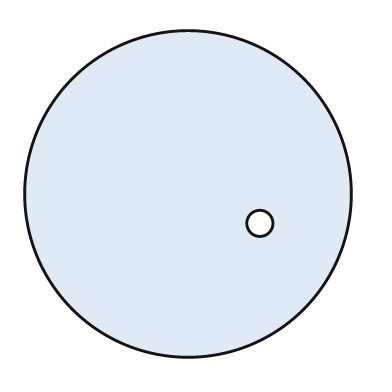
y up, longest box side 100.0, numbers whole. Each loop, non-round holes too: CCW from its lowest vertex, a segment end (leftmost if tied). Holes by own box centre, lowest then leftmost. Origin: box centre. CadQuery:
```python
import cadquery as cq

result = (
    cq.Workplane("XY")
    .moveTo(0.0, 0.0)
    .circle(50.0)
    .moveTo(22.0, -9.0)
    .circle(4.0)
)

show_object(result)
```